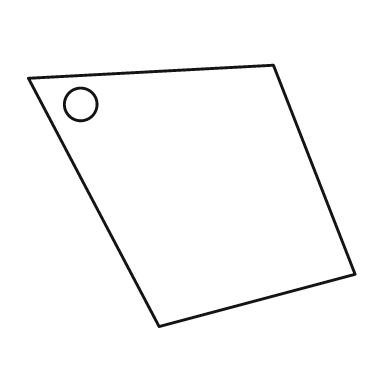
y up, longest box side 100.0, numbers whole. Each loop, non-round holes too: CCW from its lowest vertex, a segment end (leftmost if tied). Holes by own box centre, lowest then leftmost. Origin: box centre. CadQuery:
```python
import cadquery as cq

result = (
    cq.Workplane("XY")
    .moveTo(-10.0, -40.0)
    .lineTo(50.0, -24.0)
    .lineTo(25.0, 40.0)
    .lineTo(-50.0, 36.0)
    .close()
    .moveTo(-34.0, 28.0)
    .circle(5.0)
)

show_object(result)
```